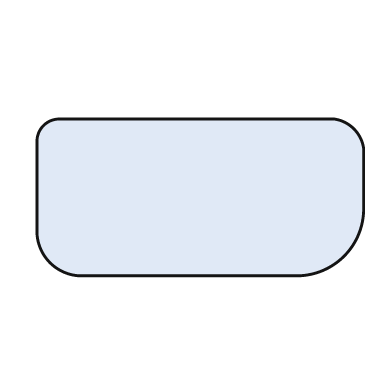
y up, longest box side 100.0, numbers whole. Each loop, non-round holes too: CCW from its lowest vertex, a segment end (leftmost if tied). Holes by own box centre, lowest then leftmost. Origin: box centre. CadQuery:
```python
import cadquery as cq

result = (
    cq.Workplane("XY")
    .moveTo(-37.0, -24.0)
    .lineTo(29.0, -24.0)
    .threePointArc((44.0, -18.0), (50.0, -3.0))
    .lineTo(50.0, 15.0)
    .threePointArc((47.0, 21.0), (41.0, 24.0))
    .lineTo(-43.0, 24.0)
    .threePointArc((-48.0, 22.0), (-50.0, 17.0))
    .lineTo(-50.0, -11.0)
    .threePointArc((-46.0, -20.0), (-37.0, -24.0))
    .close()
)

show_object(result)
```